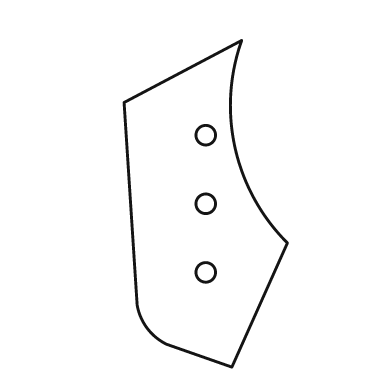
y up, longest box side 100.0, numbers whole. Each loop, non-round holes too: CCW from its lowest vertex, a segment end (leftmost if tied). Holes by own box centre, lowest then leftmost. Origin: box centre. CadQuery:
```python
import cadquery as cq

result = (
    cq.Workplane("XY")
    .moveTo(8.0, -50.0)
    .lineTo(25.0, -12.0)
    .threePointArc((9.0, 17.0), (11.0, 50.0))
    .lineTo(-25.0, 31.0)
    .lineTo(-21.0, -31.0)
    .threePointArc((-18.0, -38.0), (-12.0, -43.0))
    .close()
    .moveTo(0.0, -21.0)
    .circle(3.0)
    .moveTo(0.0, 0.0)
    .circle(3.0)
    .moveTo(0.0, 21.0)
    .circle(3.0)
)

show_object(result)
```